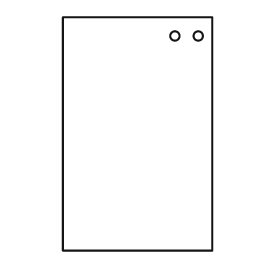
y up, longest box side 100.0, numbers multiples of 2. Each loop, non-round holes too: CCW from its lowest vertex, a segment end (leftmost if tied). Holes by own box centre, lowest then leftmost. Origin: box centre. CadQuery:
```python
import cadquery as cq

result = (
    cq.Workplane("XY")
    .moveTo(-32.0, -50.0)
    .lineTo(32.0, -50.0)
    .lineTo(32.0, 50.0)
    .lineTo(-32.0, 50.0)
    .close()
    .moveTo(16.0, 42.0)
    .circle(2.0)
    .moveTo(26.0, 42.0)
    .circle(2.0)
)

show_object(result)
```